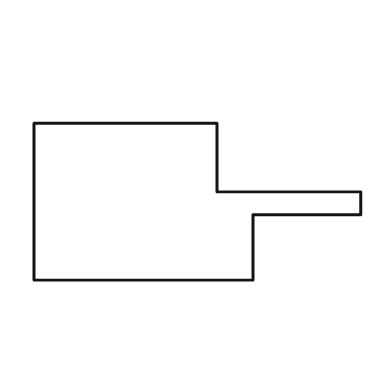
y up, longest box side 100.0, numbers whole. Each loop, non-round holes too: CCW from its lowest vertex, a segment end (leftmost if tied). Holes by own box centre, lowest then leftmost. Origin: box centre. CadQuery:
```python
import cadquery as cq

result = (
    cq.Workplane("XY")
    .moveTo(-50.0, -24.0)
    .lineTo(17.0, -24.0)
    .lineTo(17.0, -4.0)
    .lineTo(50.0, -4.0)
    .lineTo(50.0, 3.0)
    .lineTo(6.0, 3.0)
    .lineTo(6.0, 24.0)
    .lineTo(-50.0, 24.0)
    .close()
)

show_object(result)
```